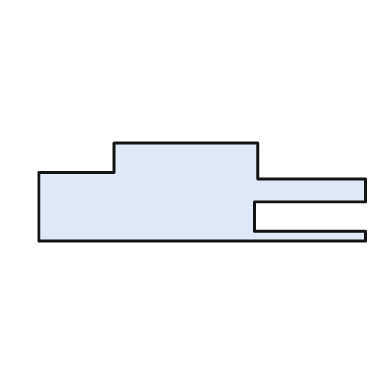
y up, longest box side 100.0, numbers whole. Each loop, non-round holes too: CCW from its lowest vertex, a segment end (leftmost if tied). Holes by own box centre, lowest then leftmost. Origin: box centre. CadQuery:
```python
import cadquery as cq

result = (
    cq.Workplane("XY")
    .moveTo(-50.0, -15.0)
    .lineTo(50.0, -15.0)
    .lineTo(50.0, -12.0)
    .lineTo(16.0, -12.0)
    .lineTo(16.0, -3.0)
    .lineTo(50.0, -3.0)
    .lineTo(50.0, 4.0)
    .lineTo(17.0, 4.0)
    .lineTo(17.0, 15.0)
    .lineTo(-27.0, 15.0)
    .lineTo(-27.0, 6.0)
    .lineTo(-50.0, 6.0)
    .close()
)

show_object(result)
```